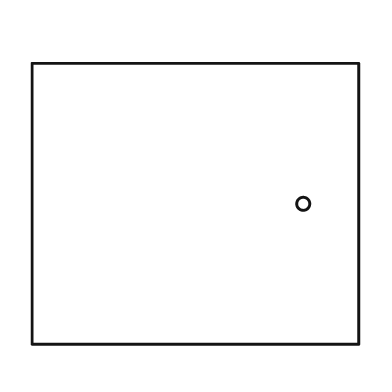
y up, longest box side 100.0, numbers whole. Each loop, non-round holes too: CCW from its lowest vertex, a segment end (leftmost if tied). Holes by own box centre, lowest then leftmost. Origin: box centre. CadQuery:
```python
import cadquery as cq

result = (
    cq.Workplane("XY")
    .moveTo(-50.0, -43.0)
    .lineTo(50.0, -43.0)
    .lineTo(50.0, 43.0)
    .lineTo(-50.0, 43.0)
    .close()
    .moveTo(33.0, 0.0)
    .circle(2.0)
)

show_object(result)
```